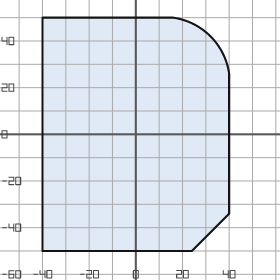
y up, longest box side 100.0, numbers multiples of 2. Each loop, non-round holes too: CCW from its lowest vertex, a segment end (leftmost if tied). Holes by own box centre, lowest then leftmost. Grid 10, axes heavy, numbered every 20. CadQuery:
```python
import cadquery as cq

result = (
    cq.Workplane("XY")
    .moveTo(-40.0, -50.0)
    .lineTo(24.0, -50.0)
    .lineTo(40.0, -34.0)
    .lineTo(40.0, 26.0)
    .threePointArc((32.0, 42.0), (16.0, 50.0))
    .lineTo(-40.0, 50.0)
    .close()
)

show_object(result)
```